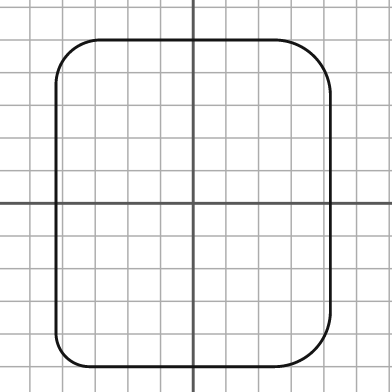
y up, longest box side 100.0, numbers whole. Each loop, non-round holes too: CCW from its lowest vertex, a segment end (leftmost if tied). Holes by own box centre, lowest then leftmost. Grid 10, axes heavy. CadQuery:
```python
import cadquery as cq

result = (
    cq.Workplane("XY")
    .moveTo(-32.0, -50.0)
    .lineTo(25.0, -50.0)
    .threePointArc((37.0, -45.0), (42.0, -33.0))
    .lineTo(42.0, 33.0)
    .threePointArc((37.0, 45.0), (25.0, 50.0))
    .lineTo(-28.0, 50.0)
    .threePointArc((-38.0, 46.0), (-42.0, 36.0))
    .lineTo(-42.0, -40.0)
    .threePointArc((-39.0, -47.0), (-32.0, -50.0))
    .close()
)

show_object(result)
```